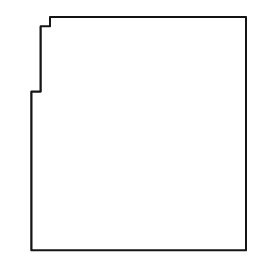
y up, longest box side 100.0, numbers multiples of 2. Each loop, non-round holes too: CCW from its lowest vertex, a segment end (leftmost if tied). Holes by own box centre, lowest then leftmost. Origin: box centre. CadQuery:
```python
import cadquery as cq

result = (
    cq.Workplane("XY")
    .moveTo(-46.0, -50.0)
    .lineTo(46.0, -50.0)
    .lineTo(46.0, 50.0)
    .lineTo(-38.0, 50.0)
    .lineTo(-38.0, 46.0)
    .lineTo(-42.0, 46.0)
    .lineTo(-42.0, 18.0)
    .lineTo(-46.0, 18.0)
    .close()
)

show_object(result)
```